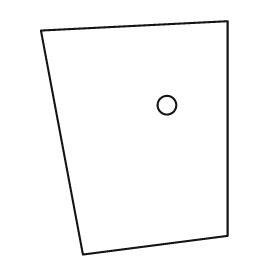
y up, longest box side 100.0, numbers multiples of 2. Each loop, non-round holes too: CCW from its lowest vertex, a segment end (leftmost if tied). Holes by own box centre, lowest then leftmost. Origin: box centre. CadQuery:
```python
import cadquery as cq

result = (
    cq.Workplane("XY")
    .moveTo(-22.0, -50.0)
    .lineTo(40.0, -42.0)
    .lineTo(40.0, 50.0)
    .lineTo(-40.0, 46.0)
    .close()
    .moveTo(14.0, 14.0)
    .circle(4.0)
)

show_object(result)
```